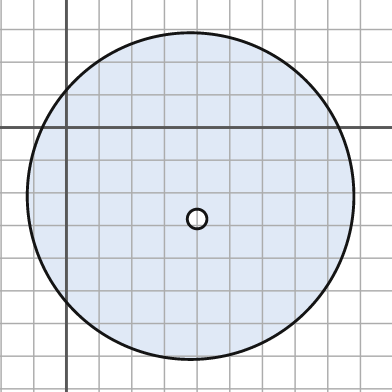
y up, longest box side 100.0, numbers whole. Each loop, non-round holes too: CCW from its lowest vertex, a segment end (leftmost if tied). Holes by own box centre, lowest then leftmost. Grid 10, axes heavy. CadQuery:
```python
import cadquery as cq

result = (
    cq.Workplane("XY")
    .moveTo(38.0, -21.0)
    .circle(50.0)
    .moveTo(40.0, -28.0)
    .circle(3.0)
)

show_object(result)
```